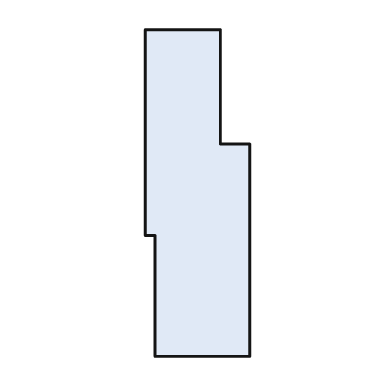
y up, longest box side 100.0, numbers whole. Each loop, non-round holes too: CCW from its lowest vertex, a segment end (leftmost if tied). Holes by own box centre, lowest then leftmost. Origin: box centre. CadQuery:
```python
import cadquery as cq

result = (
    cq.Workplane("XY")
    .moveTo(-13.0, -50.0)
    .lineTo(16.0, -50.0)
    .lineTo(16.0, 15.0)
    .lineTo(7.0, 15.0)
    .lineTo(7.0, 50.0)
    .lineTo(-16.0, 50.0)
    .lineTo(-16.0, -13.0)
    .lineTo(-13.0, -13.0)
    .close()
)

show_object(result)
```